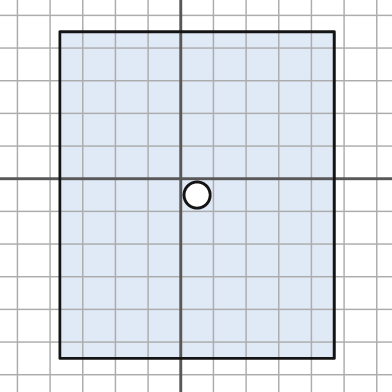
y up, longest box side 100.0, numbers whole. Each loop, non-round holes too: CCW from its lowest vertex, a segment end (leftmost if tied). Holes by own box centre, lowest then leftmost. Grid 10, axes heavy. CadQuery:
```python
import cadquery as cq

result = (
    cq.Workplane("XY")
    .moveTo(-37.0, -55.0)
    .lineTo(47.0, -55.0)
    .lineTo(47.0, 45.0)
    .lineTo(-37.0, 45.0)
    .close()
    .moveTo(5.0, -5.0)
    .circle(4.0)
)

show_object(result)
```